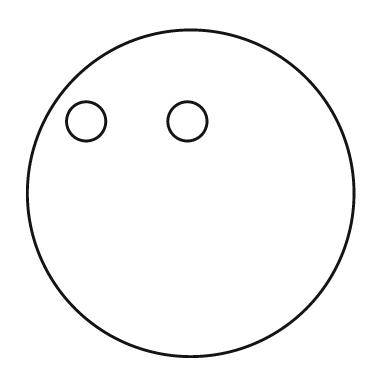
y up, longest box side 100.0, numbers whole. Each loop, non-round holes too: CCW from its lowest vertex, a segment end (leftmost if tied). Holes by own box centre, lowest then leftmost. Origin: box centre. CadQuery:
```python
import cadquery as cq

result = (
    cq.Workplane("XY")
    .moveTo(0.0, 0.0)
    .circle(50.0)
    .moveTo(-32.0, 22.0)
    .circle(6.0)
    .moveTo(-1.0, 22.0)
    .circle(6.0)
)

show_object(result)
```